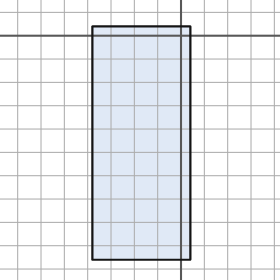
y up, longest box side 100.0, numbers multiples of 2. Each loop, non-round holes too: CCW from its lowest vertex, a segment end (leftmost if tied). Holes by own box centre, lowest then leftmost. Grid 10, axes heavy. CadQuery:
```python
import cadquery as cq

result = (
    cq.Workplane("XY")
    .moveTo(-38.0, -96.0)
    .lineTo(4.0, -96.0)
    .lineTo(4.0, 4.0)
    .lineTo(-38.0, 4.0)
    .close()
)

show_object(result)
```